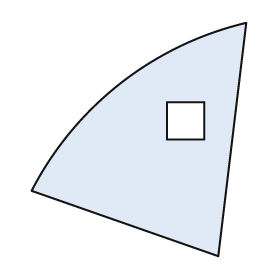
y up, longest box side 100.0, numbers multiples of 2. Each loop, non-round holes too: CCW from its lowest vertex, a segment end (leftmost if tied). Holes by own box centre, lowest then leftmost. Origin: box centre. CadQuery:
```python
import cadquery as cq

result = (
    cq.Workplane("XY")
    .moveTo(34.0, -50.0)
    .lineTo(46.0, 50.0)
    .threePointArc((-8.0, 24.0), (-46.0, -22.0))
    .close()
    .moveTo(12.0, 0.0)
    .lineTo(28.0, 0.0)
    .lineTo(28.0, 16.0)
    .lineTo(12.0, 16.0)
    .close()
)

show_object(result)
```